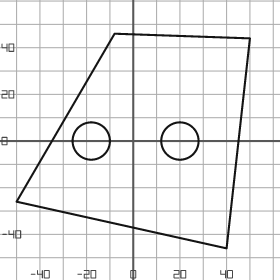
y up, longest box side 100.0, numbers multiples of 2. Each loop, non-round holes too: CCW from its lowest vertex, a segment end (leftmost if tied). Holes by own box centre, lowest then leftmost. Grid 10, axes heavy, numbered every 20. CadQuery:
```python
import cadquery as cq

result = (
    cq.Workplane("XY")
    .moveTo(40.0, -46.0)
    .lineTo(50.0, 44.0)
    .lineTo(-8.0, 46.0)
    .lineTo(-50.0, -26.0)
    .close()
    .moveTo(-18.0, 0.0)
    .circle(8.0)
    .moveTo(20.0, 0.0)
    .circle(8.0)
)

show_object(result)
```